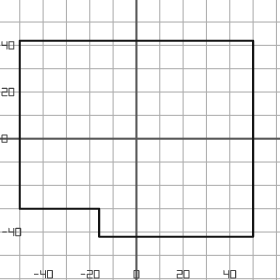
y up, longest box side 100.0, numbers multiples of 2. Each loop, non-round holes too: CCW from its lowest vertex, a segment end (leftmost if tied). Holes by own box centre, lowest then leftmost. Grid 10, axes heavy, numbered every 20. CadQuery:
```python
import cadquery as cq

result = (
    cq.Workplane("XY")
    .moveTo(-16.0, -42.0)
    .lineTo(50.0, -42.0)
    .lineTo(50.0, 42.0)
    .lineTo(-50.0, 42.0)
    .lineTo(-50.0, -30.0)
    .lineTo(-16.0, -30.0)
    .close()
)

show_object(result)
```